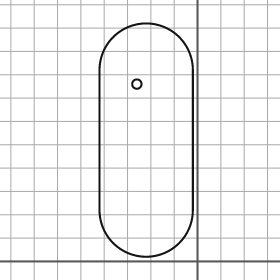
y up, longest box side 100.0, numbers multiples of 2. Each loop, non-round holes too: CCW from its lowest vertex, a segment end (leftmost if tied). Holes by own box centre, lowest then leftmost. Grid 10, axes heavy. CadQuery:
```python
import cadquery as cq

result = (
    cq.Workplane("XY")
    .moveTo(-42.0, 22.0)
    .threePointArc((-22.0, 2.0), (-2.0, 22.0))
    .lineTo(-2.0, 82.0)
    .threePointArc((-22.0, 102.0), (-42.0, 82.0))
    .close()
    .moveTo(-26.0, 76.0)
    .circle(2.0)
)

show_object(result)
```